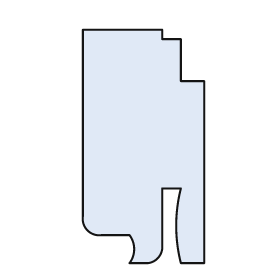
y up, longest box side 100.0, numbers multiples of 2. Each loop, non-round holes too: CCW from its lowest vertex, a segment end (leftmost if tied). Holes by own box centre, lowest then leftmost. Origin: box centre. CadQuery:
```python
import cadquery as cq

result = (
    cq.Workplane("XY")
    .moveTo(-6.0, -50.0)
    .lineTo(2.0, -50.0)
    .threePointArc((6.0, -48.0), (8.0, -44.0))
    .lineTo(8.0, -18.0)
    .lineTo(16.0, -18.0)
    .threePointArc((14.0, -34.0), (16.0, -50.0))
    .lineTo(26.0, -50.0)
    .lineTo(26.0, 28.0)
    .lineTo(16.0, 28.0)
    .lineTo(16.0, 46.0)
    .lineTo(8.0, 46.0)
    .lineTo(8.0, 50.0)
    .lineTo(-26.0, 50.0)
    .lineTo(-26.0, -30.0)
    .threePointArc((-24.0, -36.0), (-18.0, -38.0))
    .lineTo(-6.0, -38.0)
    .threePointArc((-4.0, -44.0), (-6.0, -50.0))
    .close()
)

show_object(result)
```